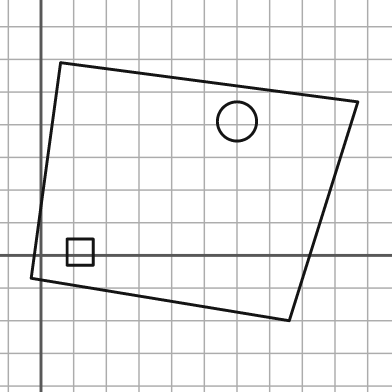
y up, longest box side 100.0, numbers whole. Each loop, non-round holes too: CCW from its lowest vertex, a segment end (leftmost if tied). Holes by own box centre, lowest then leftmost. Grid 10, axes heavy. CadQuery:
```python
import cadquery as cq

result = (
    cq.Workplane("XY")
    .moveTo(76.0, -20.0)
    .lineTo(97.0, 47.0)
    .lineTo(6.0, 59.0)
    .lineTo(-3.0, -7.0)
    .close()
    .moveTo(8.0, -3.0)
    .lineTo(16.0, -3.0)
    .lineTo(16.0, 5.0)
    .lineTo(8.0, 5.0)
    .close()
    .moveTo(60.0, 41.0)
    .circle(6.0)
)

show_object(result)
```